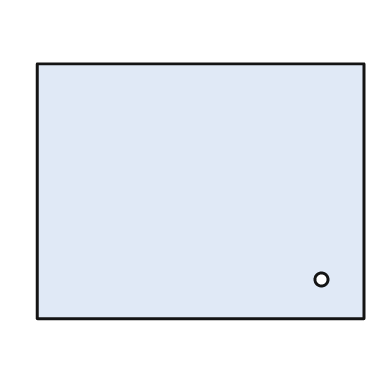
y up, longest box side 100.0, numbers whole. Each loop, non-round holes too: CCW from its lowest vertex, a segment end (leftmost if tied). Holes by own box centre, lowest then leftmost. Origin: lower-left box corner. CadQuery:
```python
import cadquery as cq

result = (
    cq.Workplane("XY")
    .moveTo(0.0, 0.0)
    .lineTo(100.0, 0.0)
    .lineTo(100.0, 78.0)
    .lineTo(0.0, 78.0)
    .close()
    .moveTo(87.0, 12.0)
    .circle(2.0)
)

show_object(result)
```